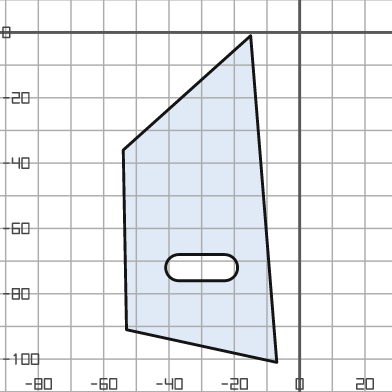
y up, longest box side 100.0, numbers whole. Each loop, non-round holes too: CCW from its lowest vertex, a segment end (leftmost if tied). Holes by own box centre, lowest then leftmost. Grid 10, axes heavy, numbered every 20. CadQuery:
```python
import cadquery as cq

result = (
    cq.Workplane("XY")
    .moveTo(-7.0, -101.0)
    .lineTo(-15.0, -1.0)
    .lineTo(-54.0, -36.0)
    .lineTo(-53.0, -91.0)
    .close()
    .moveTo(-37.0, -76.0)
    .lineTo(-23.0, -76.0)
    .threePointArc((-19.0, -72.0), (-23.0, -68.0))
    .lineTo(-37.0, -68.0)
    .threePointArc((-41.0, -72.0), (-37.0, -76.0))
    .close()
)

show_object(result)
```